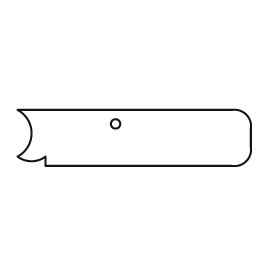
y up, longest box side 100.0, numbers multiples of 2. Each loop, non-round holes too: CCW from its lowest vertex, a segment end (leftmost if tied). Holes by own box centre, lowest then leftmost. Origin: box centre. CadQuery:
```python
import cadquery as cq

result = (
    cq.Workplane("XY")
    .moveTo(-38.0, -12.0)
    .lineTo(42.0, -12.0)
    .threePointArc((48.0, -10.0), (50.0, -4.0))
    .lineTo(50.0, 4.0)
    .threePointArc((48.0, 10.0), (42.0, 12.0))
    .lineTo(-50.0, 12.0)
    .threePointArc((-44.0, 2.0), (-50.0, -8.0))
    .threePointArc((-44.0, -10.0), (-38.0, -8.0))
    .close()
    .moveTo(-8.0, 6.0)
    .circle(2.0)
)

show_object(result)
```